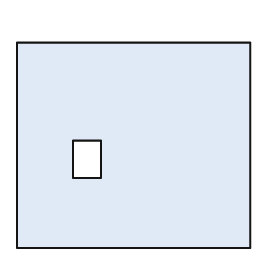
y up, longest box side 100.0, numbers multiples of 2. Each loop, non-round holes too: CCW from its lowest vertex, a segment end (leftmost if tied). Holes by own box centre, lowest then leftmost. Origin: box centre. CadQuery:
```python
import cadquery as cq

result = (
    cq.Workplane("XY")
    .moveTo(-50.0, -44.0)
    .lineTo(50.0, -44.0)
    .lineTo(50.0, 44.0)
    .lineTo(-50.0, 44.0)
    .close()
    .moveTo(-26.0, -14.0)
    .lineTo(-14.0, -14.0)
    .lineTo(-14.0, 2.0)
    .lineTo(-26.0, 2.0)
    .close()
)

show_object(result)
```